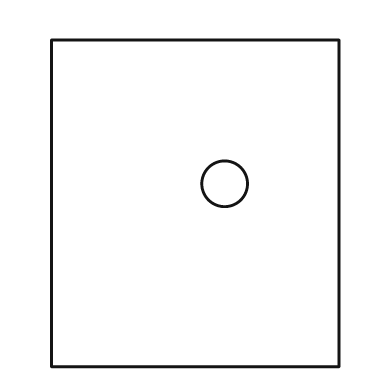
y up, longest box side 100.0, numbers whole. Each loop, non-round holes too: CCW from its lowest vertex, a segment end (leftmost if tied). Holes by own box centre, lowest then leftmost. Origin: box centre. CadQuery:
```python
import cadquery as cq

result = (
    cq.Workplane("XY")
    .moveTo(-44.0, -50.0)
    .lineTo(44.0, -50.0)
    .lineTo(44.0, 50.0)
    .lineTo(-44.0, 50.0)
    .close()
    .moveTo(9.0, 6.0)
    .circle(7.0)
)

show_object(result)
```